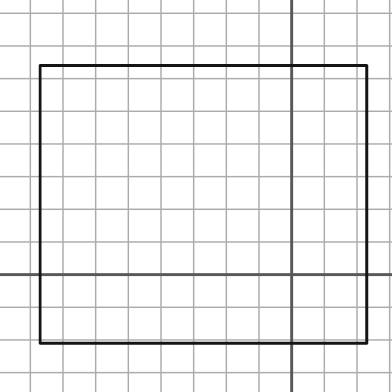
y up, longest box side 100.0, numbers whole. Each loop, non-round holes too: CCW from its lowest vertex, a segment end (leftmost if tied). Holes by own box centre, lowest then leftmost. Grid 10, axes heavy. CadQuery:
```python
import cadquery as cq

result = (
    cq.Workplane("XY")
    .moveTo(-77.0, -21.0)
    .lineTo(23.0, -21.0)
    .lineTo(23.0, 64.0)
    .lineTo(-77.0, 64.0)
    .close()
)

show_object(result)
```